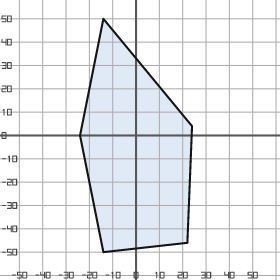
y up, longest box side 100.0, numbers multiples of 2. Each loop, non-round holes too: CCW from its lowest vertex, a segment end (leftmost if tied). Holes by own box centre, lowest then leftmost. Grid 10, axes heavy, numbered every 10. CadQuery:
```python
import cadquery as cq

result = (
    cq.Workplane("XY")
    .moveTo(-14.0, -50.0)
    .lineTo(22.0, -46.0)
    .lineTo(24.0, 4.0)
    .lineTo(-14.0, 50.0)
    .lineTo(-24.0, 0.0)
    .close()
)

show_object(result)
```